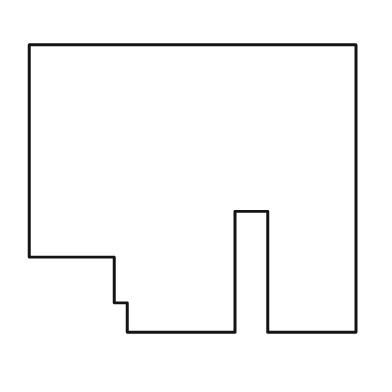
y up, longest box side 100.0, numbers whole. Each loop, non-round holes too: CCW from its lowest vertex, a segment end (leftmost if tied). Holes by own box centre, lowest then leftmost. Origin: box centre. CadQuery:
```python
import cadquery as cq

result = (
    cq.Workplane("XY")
    .moveTo(-20.0, -44.0)
    .lineTo(13.0, -44.0)
    .lineTo(13.0, -7.0)
    .lineTo(23.0, -7.0)
    .lineTo(23.0, -44.0)
    .lineTo(50.0, -44.0)
    .lineTo(50.0, 44.0)
    .lineTo(-50.0, 44.0)
    .lineTo(-50.0, -21.0)
    .lineTo(-24.0, -21.0)
    .lineTo(-24.0, -35.0)
    .lineTo(-20.0, -35.0)
    .close()
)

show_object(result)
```